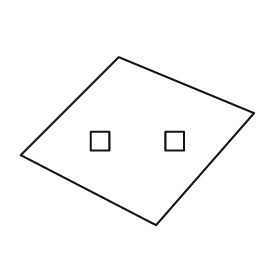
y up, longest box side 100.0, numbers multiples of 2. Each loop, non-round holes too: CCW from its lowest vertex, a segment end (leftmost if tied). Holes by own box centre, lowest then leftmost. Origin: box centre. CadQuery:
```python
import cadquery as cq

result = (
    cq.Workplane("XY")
    .moveTo(8.0, -36.0)
    .lineTo(50.0, 12.0)
    .lineTo(-8.0, 36.0)
    .lineTo(-50.0, -6.0)
    .close()
    .moveTo(-20.0, -4.0)
    .lineTo(-12.0, -4.0)
    .lineTo(-12.0, 4.0)
    .lineTo(-20.0, 4.0)
    .close()
    .moveTo(12.0, -4.0)
    .lineTo(20.0, -4.0)
    .lineTo(20.0, 4.0)
    .lineTo(12.0, 4.0)
    .close()
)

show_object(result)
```